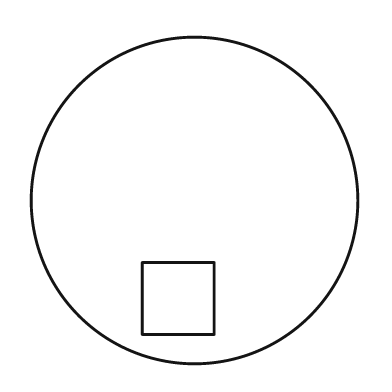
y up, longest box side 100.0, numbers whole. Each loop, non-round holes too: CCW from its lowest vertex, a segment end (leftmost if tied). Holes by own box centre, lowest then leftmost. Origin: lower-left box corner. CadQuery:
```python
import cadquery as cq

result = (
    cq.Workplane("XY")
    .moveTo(50.0, 50.0)
    .circle(50.0)
    .moveTo(34.0, 9.0)
    .lineTo(56.0, 9.0)
    .lineTo(56.0, 31.0)
    .lineTo(34.0, 31.0)
    .close()
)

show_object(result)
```